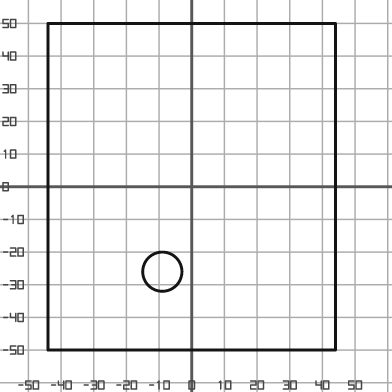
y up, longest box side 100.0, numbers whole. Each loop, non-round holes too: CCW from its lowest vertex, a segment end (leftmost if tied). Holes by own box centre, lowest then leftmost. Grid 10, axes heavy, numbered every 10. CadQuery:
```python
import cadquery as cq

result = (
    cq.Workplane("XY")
    .moveTo(-44.0, -50.0)
    .lineTo(44.0, -50.0)
    .lineTo(44.0, 50.0)
    .lineTo(-44.0, 50.0)
    .close()
    .moveTo(-9.0, -26.0)
    .circle(6.0)
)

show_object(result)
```